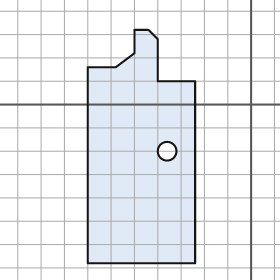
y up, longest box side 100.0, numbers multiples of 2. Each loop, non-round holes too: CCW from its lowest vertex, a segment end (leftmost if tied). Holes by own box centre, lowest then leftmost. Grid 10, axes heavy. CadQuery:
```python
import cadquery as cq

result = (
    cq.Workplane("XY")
    .moveTo(-70.0, -68.0)
    .lineTo(-24.0, -68.0)
    .lineTo(-24.0, 10.0)
    .lineTo(-40.0, 10.0)
    .lineTo(-40.0, 28.0)
    .lineTo(-44.0, 32.0)
    .lineTo(-50.0, 32.0)
    .lineTo(-50.0, 22.0)
    .lineTo(-58.0, 16.0)
    .lineTo(-70.0, 16.0)
    .close()
    .moveTo(-36.0, -20.0)
    .circle(4.0)
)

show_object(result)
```